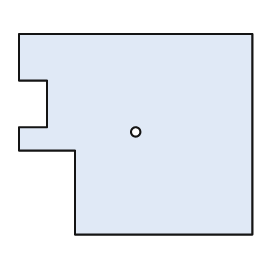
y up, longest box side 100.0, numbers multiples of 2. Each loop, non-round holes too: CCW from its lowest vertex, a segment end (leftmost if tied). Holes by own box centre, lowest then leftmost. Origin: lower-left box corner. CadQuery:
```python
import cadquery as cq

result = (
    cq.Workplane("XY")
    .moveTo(24.0, 0.0)
    .lineTo(100.0, 0.0)
    .lineTo(100.0, 86.0)
    .lineTo(0.0, 86.0)
    .lineTo(0.0, 66.0)
    .lineTo(12.0, 66.0)
    .lineTo(12.0, 46.0)
    .lineTo(0.0, 46.0)
    .lineTo(0.0, 36.0)
    .lineTo(24.0, 36.0)
    .close()
    .moveTo(50.0, 44.0)
    .circle(2.0)
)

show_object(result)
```